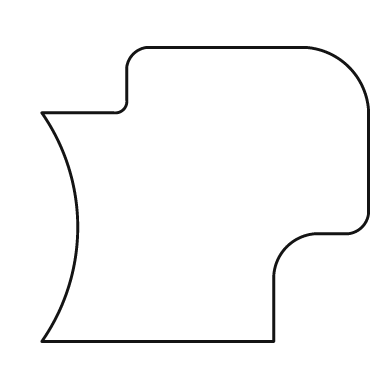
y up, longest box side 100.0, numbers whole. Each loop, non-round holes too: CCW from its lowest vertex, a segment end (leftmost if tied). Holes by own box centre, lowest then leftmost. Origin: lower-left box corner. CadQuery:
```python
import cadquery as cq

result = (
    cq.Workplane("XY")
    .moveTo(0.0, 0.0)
    .lineTo(71.0, 0.0)
    .lineTo(71.0, 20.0)
    .threePointArc((75.0, 29.0), (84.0, 33.0))
    .lineTo(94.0, 33.0)
    .threePointArc((98.0, 35.0), (100.0, 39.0))
    .lineTo(100.0, 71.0)
    .threePointArc((94.0, 84.0), (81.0, 90.0))
    .lineTo(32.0, 90.0)
    .threePointArc((28.0, 88.0), (26.0, 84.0))
    .lineTo(26.0, 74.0)
    .threePointArc((25.0, 71.0), (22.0, 70.0))
    .lineTo(0.0, 70.0)
    .threePointArc((11.0, 35.0), (0.0, 0.0))
    .close()
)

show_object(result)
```